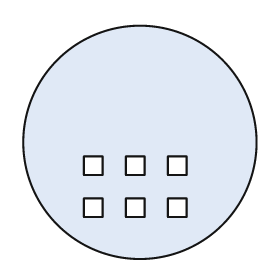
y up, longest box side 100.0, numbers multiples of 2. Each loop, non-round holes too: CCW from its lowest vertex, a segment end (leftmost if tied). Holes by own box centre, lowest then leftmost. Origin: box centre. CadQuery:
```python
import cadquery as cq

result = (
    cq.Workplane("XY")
    .moveTo(0.0, 0.0)
    .circle(50.0)
    .moveTo(-24.0, -32.0)
    .lineTo(-16.0, -32.0)
    .lineTo(-16.0, -24.0)
    .lineTo(-24.0, -24.0)
    .close()
    .moveTo(-6.0, -32.0)
    .lineTo(2.0, -32.0)
    .lineTo(2.0, -24.0)
    .lineTo(-6.0, -24.0)
    .close()
    .moveTo(12.0, -32.0)
    .lineTo(20.0, -32.0)
    .lineTo(20.0, -24.0)
    .lineTo(12.0, -24.0)
    .close()
    .moveTo(-24.0, -14.0)
    .lineTo(-16.0, -14.0)
    .lineTo(-16.0, -6.0)
    .lineTo(-24.0, -6.0)
    .close()
    .moveTo(-6.0, -14.0)
    .lineTo(2.0, -14.0)
    .lineTo(2.0, -6.0)
    .lineTo(-6.0, -6.0)
    .close()
    .moveTo(12.0, -14.0)
    .lineTo(20.0, -14.0)
    .lineTo(20.0, -6.0)
    .lineTo(12.0, -6.0)
    .close()
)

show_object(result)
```